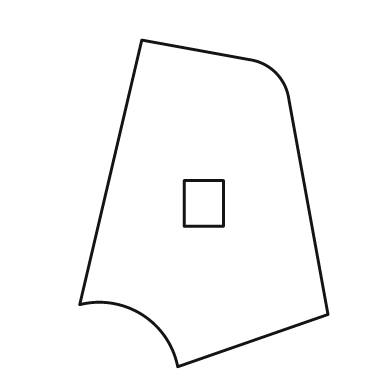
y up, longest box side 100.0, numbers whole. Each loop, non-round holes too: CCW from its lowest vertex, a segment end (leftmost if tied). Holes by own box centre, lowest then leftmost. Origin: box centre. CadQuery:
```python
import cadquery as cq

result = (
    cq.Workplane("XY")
    .moveTo(-8.0, -50.0)
    .lineTo(38.0, -34.0)
    .lineTo(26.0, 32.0)
    .threePointArc((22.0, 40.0), (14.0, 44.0))
    .lineTo(-19.0, 50.0)
    .lineTo(-38.0, -31.0)
    .threePointArc((-19.0, -34.0), (-8.0, -50.0))
    .close()
    .moveTo(-6.0, -7.0)
    .lineTo(6.0, -7.0)
    .lineTo(6.0, 7.0)
    .lineTo(-6.0, 7.0)
    .close()
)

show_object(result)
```